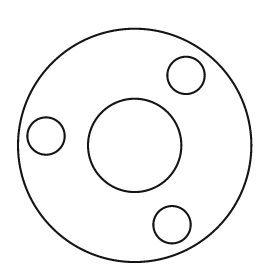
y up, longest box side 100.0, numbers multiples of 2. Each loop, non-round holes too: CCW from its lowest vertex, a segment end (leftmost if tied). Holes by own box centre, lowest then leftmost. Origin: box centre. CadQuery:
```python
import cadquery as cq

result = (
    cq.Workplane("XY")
    .moveTo(0.0, 0.0)
    .circle(50.0)
    .moveTo(16.0, -34.0)
    .circle(8.0)
    .moveTo(0.0, 0.0)
    .circle(20.0)
    .moveTo(-38.0, 4.0)
    .circle(8.0)
    .moveTo(22.0, 30.0)
    .circle(8.0)
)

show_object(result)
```